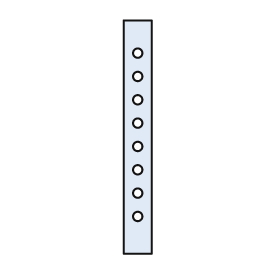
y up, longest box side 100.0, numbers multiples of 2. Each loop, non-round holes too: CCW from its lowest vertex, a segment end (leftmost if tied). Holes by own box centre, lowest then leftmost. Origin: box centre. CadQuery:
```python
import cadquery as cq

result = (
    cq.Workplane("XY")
    .moveTo(-6.0, -50.0)
    .lineTo(6.0, -50.0)
    .lineTo(6.0, 50.0)
    .lineTo(-6.0, 50.0)
    .close()
    .moveTo(0.0, -34.0)
    .circle(2.0)
    .moveTo(0.0, -24.0)
    .circle(2.0)
    .moveTo(0.0, -14.0)
    .circle(2.0)
    .moveTo(0.0, -4.0)
    .circle(2.0)
    .moveTo(0.0, 6.0)
    .circle(2.0)
    .moveTo(0.0, 16.0)
    .circle(2.0)
    .moveTo(0.0, 26.0)
    .circle(2.0)
    .moveTo(0.0, 36.0)
    .circle(2.0)
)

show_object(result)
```